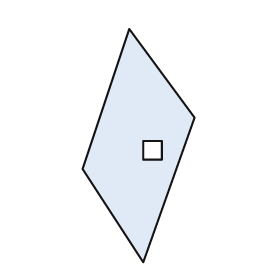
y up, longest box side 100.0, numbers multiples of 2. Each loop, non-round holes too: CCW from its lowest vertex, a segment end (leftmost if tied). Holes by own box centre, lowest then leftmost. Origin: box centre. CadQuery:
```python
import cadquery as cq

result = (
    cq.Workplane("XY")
    .moveTo(2.0, -50.0)
    .lineTo(24.0, 12.0)
    .lineTo(-4.0, 50.0)
    .lineTo(-24.0, -10.0)
    .close()
    .moveTo(2.0, -6.0)
    .lineTo(10.0, -6.0)
    .lineTo(10.0, 2.0)
    .lineTo(2.0, 2.0)
    .close()
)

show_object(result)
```